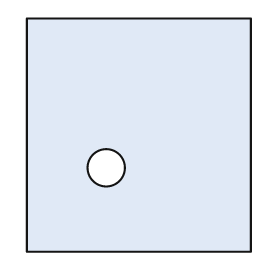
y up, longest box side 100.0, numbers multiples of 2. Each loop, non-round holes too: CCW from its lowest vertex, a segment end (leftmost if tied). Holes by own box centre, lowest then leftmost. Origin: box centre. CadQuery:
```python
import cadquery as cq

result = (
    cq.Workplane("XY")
    .moveTo(-48.0, -50.0)
    .lineTo(48.0, -50.0)
    .lineTo(48.0, 50.0)
    .lineTo(-48.0, 50.0)
    .close()
    .moveTo(-14.0, -14.0)
    .circle(8.0)
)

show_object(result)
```